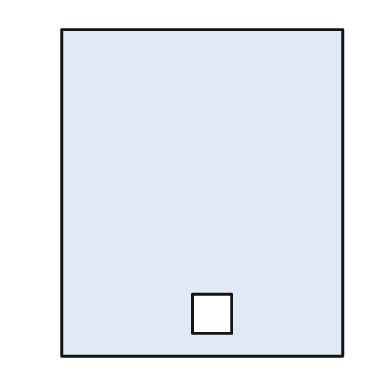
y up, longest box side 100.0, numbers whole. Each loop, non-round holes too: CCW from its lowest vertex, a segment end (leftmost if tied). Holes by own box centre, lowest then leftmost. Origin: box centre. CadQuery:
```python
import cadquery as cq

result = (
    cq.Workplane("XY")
    .moveTo(-43.0, -50.0)
    .lineTo(43.0, -50.0)
    .lineTo(43.0, 50.0)
    .lineTo(-43.0, 50.0)
    .close()
    .moveTo(-3.0, -43.0)
    .lineTo(9.0, -43.0)
    .lineTo(9.0, -31.0)
    .lineTo(-3.0, -31.0)
    .close()
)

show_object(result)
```